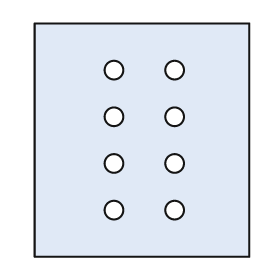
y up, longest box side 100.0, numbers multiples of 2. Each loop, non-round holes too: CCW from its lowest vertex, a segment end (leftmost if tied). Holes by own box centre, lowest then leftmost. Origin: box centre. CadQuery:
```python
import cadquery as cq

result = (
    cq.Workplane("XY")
    .moveTo(-46.0, -50.0)
    .lineTo(46.0, -50.0)
    .lineTo(46.0, 50.0)
    .lineTo(-46.0, 50.0)
    .close()
    .moveTo(-12.0, -30.0)
    .circle(4.0)
    .moveTo(14.0, -30.0)
    .circle(4.0)
    .moveTo(-12.0, -10.0)
    .circle(4.0)
    .moveTo(14.0, -10.0)
    .circle(4.0)
    .moveTo(-12.0, 10.0)
    .circle(4.0)
    .moveTo(14.0, 10.0)
    .circle(4.0)
    .moveTo(-12.0, 30.0)
    .circle(4.0)
    .moveTo(14.0, 30.0)
    .circle(4.0)
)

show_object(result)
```